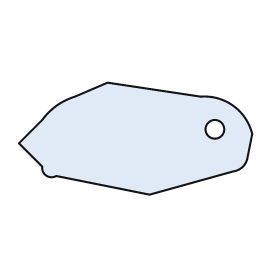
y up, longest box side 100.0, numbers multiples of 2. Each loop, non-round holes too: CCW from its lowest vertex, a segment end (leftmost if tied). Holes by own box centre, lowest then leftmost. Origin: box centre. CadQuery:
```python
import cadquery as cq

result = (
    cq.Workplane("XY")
    .moveTo(6.0, -24.0)
    .lineTo(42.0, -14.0)
    .threePointArc((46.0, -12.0), (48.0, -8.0))
    .lineTo(50.0, 2.0)
    .threePointArc((42.0, 14.0), (28.0, 18.0))
    .lineTo(-12.0, 24.0)
    .lineTo(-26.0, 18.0)
    .threePointArc((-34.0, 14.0), (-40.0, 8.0))
    .lineTo(-50.0, -2.0)
    .lineTo(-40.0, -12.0)
    .threePointArc((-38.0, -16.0), (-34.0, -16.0))
    .close()
    .moveTo(34.0, 4.0)
    .circle(4.0)
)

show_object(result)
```